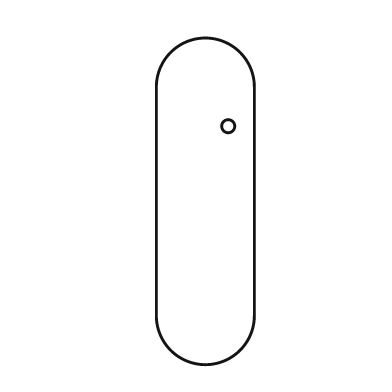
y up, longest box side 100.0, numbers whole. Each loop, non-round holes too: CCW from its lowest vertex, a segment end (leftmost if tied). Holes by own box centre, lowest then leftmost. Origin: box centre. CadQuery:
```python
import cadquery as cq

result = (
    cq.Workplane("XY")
    .moveTo(-15.0, -35.0)
    .threePointArc((0.0, -50.0), (15.0, -35.0))
    .lineTo(15.0, 35.0)
    .threePointArc((0.0, 50.0), (-15.0, 35.0))
    .close()
    .moveTo(7.0, 23.0)
    .circle(2.0)
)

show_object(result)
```